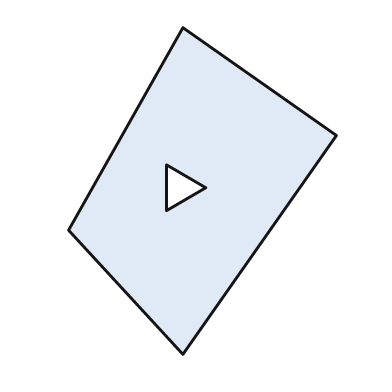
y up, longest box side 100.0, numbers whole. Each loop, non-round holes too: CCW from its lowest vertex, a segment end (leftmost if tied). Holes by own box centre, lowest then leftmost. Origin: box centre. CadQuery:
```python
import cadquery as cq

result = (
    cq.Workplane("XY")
    .moveTo(-6.0, -50.0)
    .lineTo(41.0, 17.0)
    .lineTo(-6.0, 50.0)
    .lineTo(-41.0, -12.0)
    .close()
    .moveTo(-11.0, -6.0)
    .lineTo(1.0, 1.0)
    .lineTo(-11.0, 8.0)
    .close()
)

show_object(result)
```